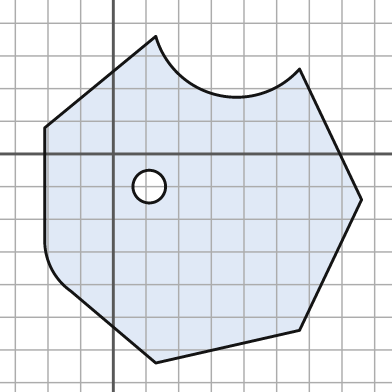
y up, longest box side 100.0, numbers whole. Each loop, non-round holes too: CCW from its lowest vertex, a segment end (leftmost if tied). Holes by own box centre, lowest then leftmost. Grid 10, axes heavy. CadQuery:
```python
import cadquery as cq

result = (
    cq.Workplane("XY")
    .moveTo(13.0, -64.0)
    .lineTo(57.0, -54.0)
    .lineTo(76.0, -14.0)
    .lineTo(57.0, 26.0)
    .threePointArc((32.0, 18.0), (13.0, 36.0))
    .lineTo(-21.0, 8.0)
    .lineTo(-21.0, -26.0)
    .threePointArc((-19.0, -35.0), (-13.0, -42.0))
    .close()
    .moveTo(11.0, -10.0)
    .circle(5.0)
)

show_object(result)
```